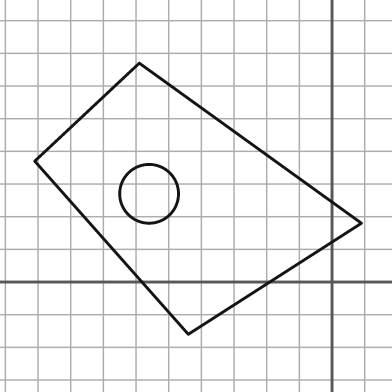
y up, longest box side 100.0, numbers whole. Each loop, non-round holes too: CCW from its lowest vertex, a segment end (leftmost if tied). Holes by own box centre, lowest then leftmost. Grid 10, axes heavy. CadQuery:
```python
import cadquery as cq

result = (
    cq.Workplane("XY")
    .moveTo(-44.0, -16.0)
    .lineTo(9.0, 18.0)
    .lineTo(-59.0, 67.0)
    .lineTo(-91.0, 37.0)
    .close()
    .moveTo(-56.0, 27.0)
    .circle(9.0)
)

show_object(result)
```